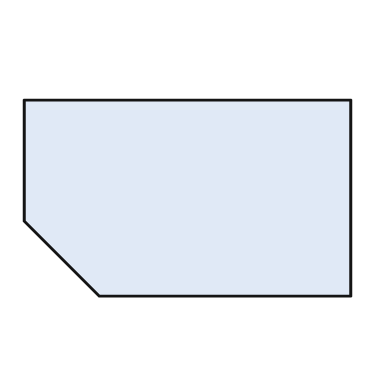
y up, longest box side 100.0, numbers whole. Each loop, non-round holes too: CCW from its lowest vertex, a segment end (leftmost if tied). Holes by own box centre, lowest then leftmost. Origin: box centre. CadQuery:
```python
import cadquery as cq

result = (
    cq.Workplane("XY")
    .moveTo(-27.0, -30.0)
    .lineTo(50.0, -30.0)
    .lineTo(50.0, 30.0)
    .lineTo(-50.0, 30.0)
    .lineTo(-50.0, -7.0)
    .close()
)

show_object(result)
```